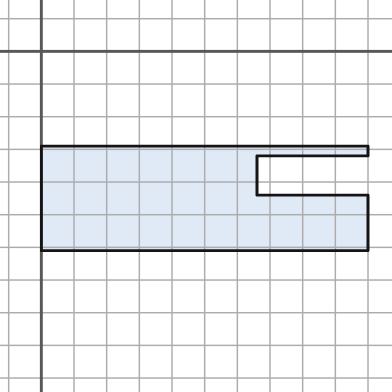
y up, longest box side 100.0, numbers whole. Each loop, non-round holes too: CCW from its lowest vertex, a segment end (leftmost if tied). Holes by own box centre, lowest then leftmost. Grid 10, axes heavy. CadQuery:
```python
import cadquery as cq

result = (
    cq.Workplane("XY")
    .moveTo(0.0, -61.0)
    .lineTo(100.0, -61.0)
    .lineTo(100.0, -44.0)
    .lineTo(66.0, -44.0)
    .lineTo(66.0, -32.0)
    .lineTo(100.0, -32.0)
    .lineTo(100.0, -29.0)
    .lineTo(0.0, -29.0)
    .close()
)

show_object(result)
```